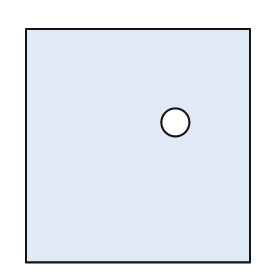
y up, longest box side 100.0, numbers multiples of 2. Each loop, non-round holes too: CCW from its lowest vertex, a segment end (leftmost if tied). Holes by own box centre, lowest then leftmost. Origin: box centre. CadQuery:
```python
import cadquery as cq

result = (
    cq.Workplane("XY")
    .moveTo(-48.0, -50.0)
    .lineTo(48.0, -50.0)
    .lineTo(48.0, 50.0)
    .lineTo(-48.0, 50.0)
    .close()
    .moveTo(16.0, 10.0)
    .circle(6.0)
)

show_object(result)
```